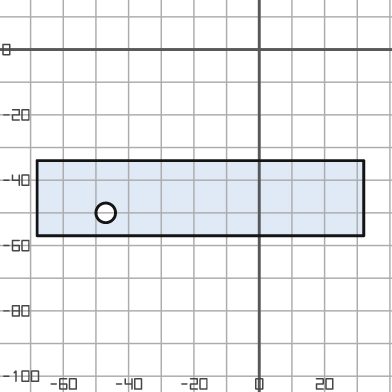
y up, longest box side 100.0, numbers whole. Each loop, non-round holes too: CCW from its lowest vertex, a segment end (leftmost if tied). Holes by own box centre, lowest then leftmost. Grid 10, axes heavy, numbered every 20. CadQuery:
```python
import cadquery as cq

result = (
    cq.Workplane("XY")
    .moveTo(-68.0, -57.0)
    .lineTo(32.0, -57.0)
    .lineTo(32.0, -34.0)
    .lineTo(-68.0, -34.0)
    .close()
    .moveTo(-47.0, -50.0)
    .circle(3.0)
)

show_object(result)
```